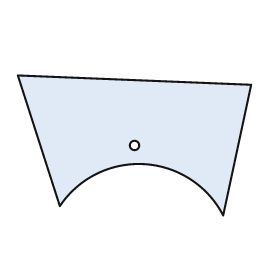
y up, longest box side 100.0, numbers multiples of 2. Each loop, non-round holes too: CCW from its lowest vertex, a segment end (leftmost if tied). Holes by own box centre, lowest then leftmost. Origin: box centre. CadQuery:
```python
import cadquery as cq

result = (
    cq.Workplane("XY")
    .moveTo(38.0, -30.0)
    .lineTo(50.0, 26.0)
    .lineTo(-50.0, 30.0)
    .lineTo(-32.0, -26.0)
    .threePointArc((4.0, -8.0), (38.0, -30.0))
    .close()
    .moveTo(0.0, 0.0)
    .circle(2.0)
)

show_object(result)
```